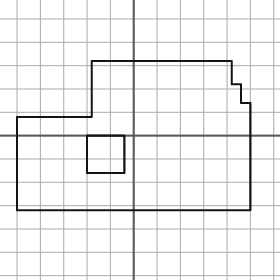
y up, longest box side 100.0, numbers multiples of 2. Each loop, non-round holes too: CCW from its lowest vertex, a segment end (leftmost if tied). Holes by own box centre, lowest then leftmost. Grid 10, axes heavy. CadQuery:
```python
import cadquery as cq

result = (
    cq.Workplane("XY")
    .moveTo(-50.0, -32.0)
    .lineTo(50.0, -32.0)
    .lineTo(50.0, 14.0)
    .lineTo(46.0, 14.0)
    .lineTo(46.0, 22.0)
    .lineTo(42.0, 22.0)
    .lineTo(42.0, 32.0)
    .lineTo(-18.0, 32.0)
    .lineTo(-18.0, 8.0)
    .lineTo(-50.0, 8.0)
    .close()
    .moveTo(-20.0, -16.0)
    .lineTo(-4.0, -16.0)
    .lineTo(-4.0, 0.0)
    .lineTo(-20.0, 0.0)
    .close()
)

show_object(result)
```